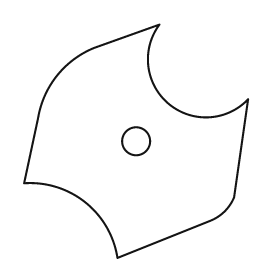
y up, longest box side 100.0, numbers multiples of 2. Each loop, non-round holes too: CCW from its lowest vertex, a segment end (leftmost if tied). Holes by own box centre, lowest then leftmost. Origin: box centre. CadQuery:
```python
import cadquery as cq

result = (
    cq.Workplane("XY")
    .moveTo(-8.0, -50.0)
    .lineTo(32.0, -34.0)
    .threePointArc((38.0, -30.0), (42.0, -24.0))
    .lineTo(48.0, 18.0)
    .threePointArc((14.0, 16.0), (10.0, 50.0))
    .lineTo(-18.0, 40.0)
    .threePointArc((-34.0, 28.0), (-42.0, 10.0))
    .lineTo(-48.0, -18.0)
    .threePointArc((-22.0, -26.0), (-8.0, -50.0))
    .close()
    .moveTo(0.0, 0.0)
    .circle(6.0)
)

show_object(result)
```